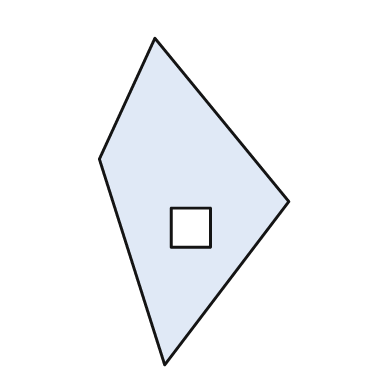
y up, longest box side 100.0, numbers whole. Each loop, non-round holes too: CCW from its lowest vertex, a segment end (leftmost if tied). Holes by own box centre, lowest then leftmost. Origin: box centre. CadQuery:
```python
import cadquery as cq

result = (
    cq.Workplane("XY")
    .moveTo(-9.0, -50.0)
    .lineTo(29.0, 0.0)
    .lineTo(-12.0, 50.0)
    .lineTo(-29.0, 13.0)
    .close()
    .moveTo(-7.0, -14.0)
    .lineTo(5.0, -14.0)
    .lineTo(5.0, -2.0)
    .lineTo(-7.0, -2.0)
    .close()
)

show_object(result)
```